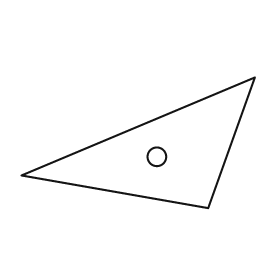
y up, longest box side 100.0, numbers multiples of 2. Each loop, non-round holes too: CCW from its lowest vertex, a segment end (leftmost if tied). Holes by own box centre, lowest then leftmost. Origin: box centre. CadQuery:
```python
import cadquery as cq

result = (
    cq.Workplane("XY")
    .moveTo(30.0, -28.0)
    .lineTo(50.0, 28.0)
    .lineTo(-50.0, -14.0)
    .close()
    .moveTo(8.0, -6.0)
    .circle(4.0)
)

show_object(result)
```